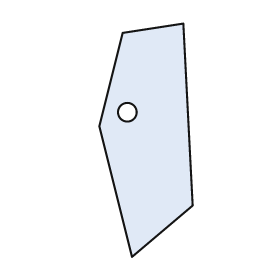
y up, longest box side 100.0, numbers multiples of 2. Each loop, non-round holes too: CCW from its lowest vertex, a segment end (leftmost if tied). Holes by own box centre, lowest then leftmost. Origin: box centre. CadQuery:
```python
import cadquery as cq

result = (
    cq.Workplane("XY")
    .moveTo(-6.0, -50.0)
    .lineTo(20.0, -28.0)
    .lineTo(16.0, 50.0)
    .lineTo(-10.0, 46.0)
    .lineTo(-20.0, 6.0)
    .close()
    .moveTo(-8.0, 12.0)
    .circle(4.0)
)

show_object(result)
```